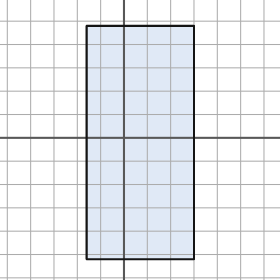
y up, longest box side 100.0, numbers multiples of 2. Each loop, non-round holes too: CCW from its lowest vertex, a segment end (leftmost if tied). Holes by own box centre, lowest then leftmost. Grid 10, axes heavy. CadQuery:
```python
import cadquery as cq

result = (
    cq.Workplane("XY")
    .moveTo(-16.0, -52.0)
    .lineTo(30.0, -52.0)
    .lineTo(30.0, 48.0)
    .lineTo(-16.0, 48.0)
    .close()
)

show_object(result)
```